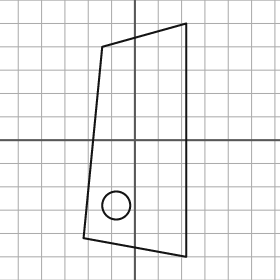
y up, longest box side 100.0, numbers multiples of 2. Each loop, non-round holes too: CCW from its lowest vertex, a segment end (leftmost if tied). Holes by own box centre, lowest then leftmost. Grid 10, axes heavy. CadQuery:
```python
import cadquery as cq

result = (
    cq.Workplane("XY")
    .moveTo(22.0, -50.0)
    .lineTo(22.0, 50.0)
    .lineTo(-14.0, 40.0)
    .lineTo(-22.0, -42.0)
    .close()
    .moveTo(-8.0, -28.0)
    .circle(6.0)
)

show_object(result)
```